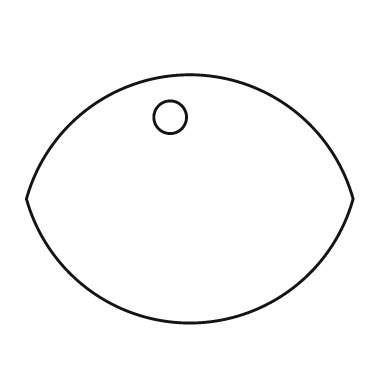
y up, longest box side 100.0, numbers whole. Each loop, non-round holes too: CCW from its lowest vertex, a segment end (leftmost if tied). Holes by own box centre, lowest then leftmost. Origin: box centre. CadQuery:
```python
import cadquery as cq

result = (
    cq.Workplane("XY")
    .moveTo(-50.0, 0.0)
    .threePointArc((0.0, -38.0), (50.0, 0.0))
    .threePointArc((0.0, 38.0), (-50.0, 0.0))
    .close()
    .moveTo(-6.0, 25.0)
    .circle(5.0)
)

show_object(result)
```